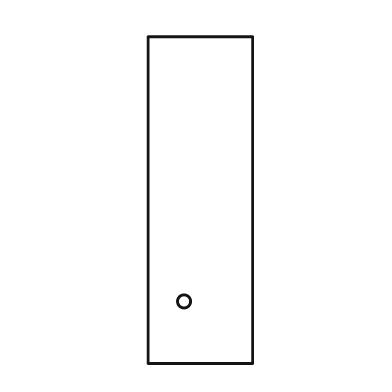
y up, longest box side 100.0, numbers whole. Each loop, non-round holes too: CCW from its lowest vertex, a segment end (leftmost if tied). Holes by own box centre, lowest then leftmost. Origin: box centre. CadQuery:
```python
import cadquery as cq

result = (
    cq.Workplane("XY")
    .moveTo(-16.0, -50.0)
    .lineTo(16.0, -50.0)
    .lineTo(16.0, 50.0)
    .lineTo(-16.0, 50.0)
    .close()
    .moveTo(-5.0, -31.0)
    .circle(2.0)
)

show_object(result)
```